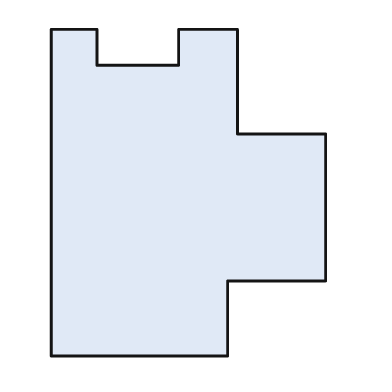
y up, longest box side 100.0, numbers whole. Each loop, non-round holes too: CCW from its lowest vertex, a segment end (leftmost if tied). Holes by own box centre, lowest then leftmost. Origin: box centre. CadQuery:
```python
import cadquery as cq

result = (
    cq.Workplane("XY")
    .moveTo(-42.0, -50.0)
    .lineTo(12.0, -50.0)
    .lineTo(12.0, -27.0)
    .lineTo(42.0, -27.0)
    .lineTo(42.0, 18.0)
    .lineTo(15.0, 18.0)
    .lineTo(15.0, 50.0)
    .lineTo(-3.0, 50.0)
    .lineTo(-3.0, 39.0)
    .lineTo(-28.0, 39.0)
    .lineTo(-28.0, 50.0)
    .lineTo(-42.0, 50.0)
    .close()
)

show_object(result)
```